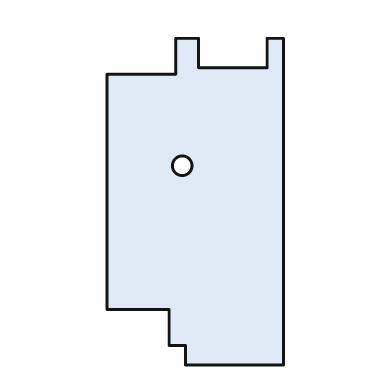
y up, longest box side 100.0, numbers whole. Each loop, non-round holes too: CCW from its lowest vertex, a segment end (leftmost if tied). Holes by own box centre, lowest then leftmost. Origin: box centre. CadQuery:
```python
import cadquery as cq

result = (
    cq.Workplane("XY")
    .moveTo(-3.0, -50.0)
    .lineTo(27.0, -50.0)
    .lineTo(27.0, 50.0)
    .lineTo(22.0, 50.0)
    .lineTo(22.0, 41.0)
    .lineTo(1.0, 41.0)
    .lineTo(1.0, 50.0)
    .lineTo(-6.0, 50.0)
    .lineTo(-6.0, 39.0)
    .lineTo(-27.0, 39.0)
    .lineTo(-27.0, -33.0)
    .lineTo(-8.0, -33.0)
    .lineTo(-8.0, -44.0)
    .lineTo(-3.0, -44.0)
    .close()
    .moveTo(-4.0, 11.0)
    .circle(3.0)
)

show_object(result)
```